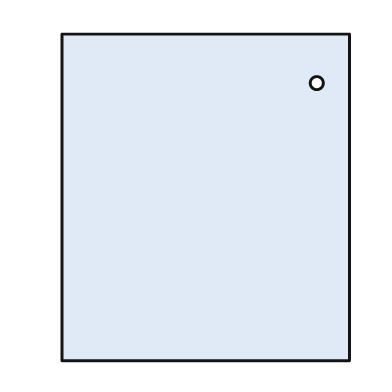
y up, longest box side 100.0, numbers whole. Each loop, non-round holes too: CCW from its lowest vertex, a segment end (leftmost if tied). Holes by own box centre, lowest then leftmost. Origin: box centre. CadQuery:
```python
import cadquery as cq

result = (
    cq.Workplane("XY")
    .moveTo(-44.0, -50.0)
    .lineTo(44.0, -50.0)
    .lineTo(44.0, 50.0)
    .lineTo(-44.0, 50.0)
    .close()
    .moveTo(34.0, 35.0)
    .circle(2.0)
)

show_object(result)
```